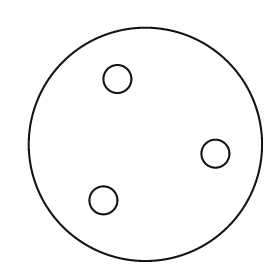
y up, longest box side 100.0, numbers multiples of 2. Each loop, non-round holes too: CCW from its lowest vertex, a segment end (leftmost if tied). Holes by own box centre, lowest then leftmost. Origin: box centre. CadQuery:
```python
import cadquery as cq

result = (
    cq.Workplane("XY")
    .moveTo(0.0, 0.0)
    .circle(50.0)
    .moveTo(-18.0, -24.0)
    .circle(6.0)
    .moveTo(30.0, -4.0)
    .circle(6.0)
    .moveTo(-12.0, 28.0)
    .circle(6.0)
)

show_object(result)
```